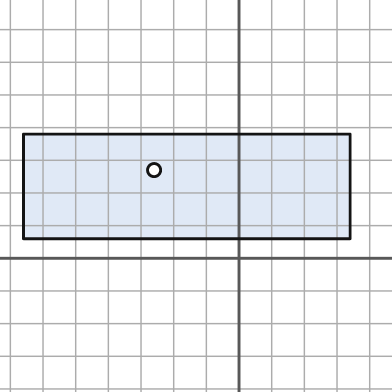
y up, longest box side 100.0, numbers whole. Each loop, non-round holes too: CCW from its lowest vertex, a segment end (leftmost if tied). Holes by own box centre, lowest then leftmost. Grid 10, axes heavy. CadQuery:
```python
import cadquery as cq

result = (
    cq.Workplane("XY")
    .moveTo(-66.0, 6.0)
    .lineTo(34.0, 6.0)
    .lineTo(34.0, 38.0)
    .lineTo(-66.0, 38.0)
    .close()
    .moveTo(-26.0, 27.0)
    .circle(2.0)
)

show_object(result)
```